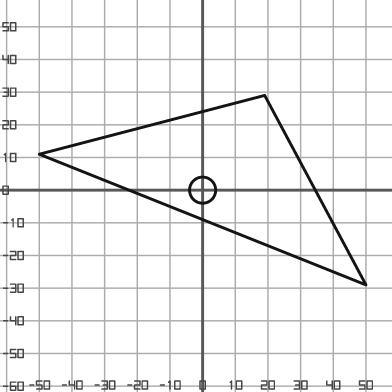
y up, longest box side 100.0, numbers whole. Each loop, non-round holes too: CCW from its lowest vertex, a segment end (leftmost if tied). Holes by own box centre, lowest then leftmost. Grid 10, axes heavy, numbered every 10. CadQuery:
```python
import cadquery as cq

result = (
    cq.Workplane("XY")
    .moveTo(50.0, -29.0)
    .lineTo(19.0, 29.0)
    .lineTo(-50.0, 11.0)
    .close()
    .moveTo(0.0, 0.0)
    .circle(4.0)
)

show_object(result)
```